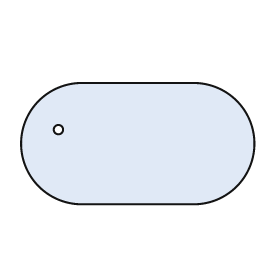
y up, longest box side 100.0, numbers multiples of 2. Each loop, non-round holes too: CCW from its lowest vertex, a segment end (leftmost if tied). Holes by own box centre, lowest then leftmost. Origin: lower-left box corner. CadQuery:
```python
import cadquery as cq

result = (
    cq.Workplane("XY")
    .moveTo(26.0, 0.0)
    .lineTo(74.0, 0.0)
    .threePointArc((100.0, 26.0), (74.0, 52.0))
    .lineTo(26.0, 52.0)
    .threePointArc((0.0, 26.0), (26.0, 0.0))
    .close()
    .moveTo(16.0, 32.0)
    .circle(2.0)
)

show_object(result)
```